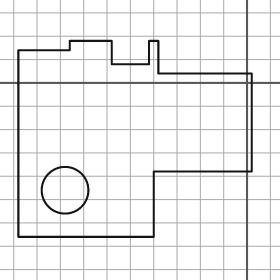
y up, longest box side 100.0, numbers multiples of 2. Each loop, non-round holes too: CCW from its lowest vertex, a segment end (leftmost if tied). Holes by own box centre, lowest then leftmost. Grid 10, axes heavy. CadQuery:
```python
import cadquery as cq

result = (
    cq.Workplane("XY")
    .moveTo(-98.0, -66.0)
    .lineTo(-40.0, -66.0)
    .lineTo(-40.0, -38.0)
    .lineTo(2.0, -38.0)
    .lineTo(2.0, 4.0)
    .lineTo(-38.0, 4.0)
    .lineTo(-38.0, 18.0)
    .lineTo(-42.0, 18.0)
    .lineTo(-42.0, 8.0)
    .lineTo(-58.0, 8.0)
    .lineTo(-58.0, 18.0)
    .lineTo(-76.0, 18.0)
    .lineTo(-76.0, 14.0)
    .lineTo(-98.0, 14.0)
    .close()
    .moveTo(-78.0, -46.0)
    .circle(10.0)
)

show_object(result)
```